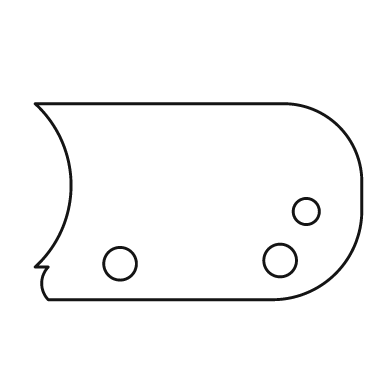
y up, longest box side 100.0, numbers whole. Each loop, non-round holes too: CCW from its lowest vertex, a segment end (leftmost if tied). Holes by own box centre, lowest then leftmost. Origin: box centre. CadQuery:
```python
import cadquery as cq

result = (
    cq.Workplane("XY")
    .moveTo(-46.0, -30.0)
    .lineTo(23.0, -30.0)
    .threePointArc((42.0, -22.0), (50.0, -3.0))
    .lineTo(50.0, 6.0)
    .threePointArc((43.0, 23.0), (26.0, 30.0))
    .lineTo(-50.0, 30.0)
    .threePointArc((-39.0, 5.0), (-50.0, -20.0))
    .lineTo(-46.0, -20.0)
    .threePointArc((-48.0, -25.0), (-46.0, -30.0))
    .close()
    .moveTo(-24.0, -19.0)
    .circle(5.0)
    .moveTo(25.0, -18.0)
    .circle(5.0)
    .moveTo(33.0, -3.0)
    .circle(4.0)
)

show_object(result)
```